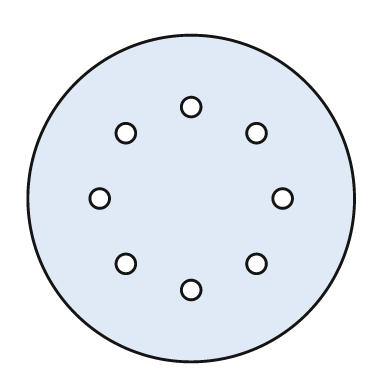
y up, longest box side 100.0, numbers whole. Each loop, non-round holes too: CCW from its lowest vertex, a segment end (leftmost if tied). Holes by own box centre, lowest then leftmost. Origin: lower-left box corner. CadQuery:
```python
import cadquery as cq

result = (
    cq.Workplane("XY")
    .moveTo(50.0, 50.0)
    .circle(50.0)
    .moveTo(50.0, 22.0)
    .circle(3.0)
    .moveTo(30.0, 30.0)
    .circle(3.0)
    .moveTo(70.0, 30.0)
    .circle(3.0)
    .moveTo(22.0, 50.0)
    .circle(3.0)
    .moveTo(78.0, 50.0)
    .circle(3.0)
    .moveTo(30.0, 70.0)
    .circle(3.0)
    .moveTo(70.0, 70.0)
    .circle(3.0)
    .moveTo(50.0, 78.0)
    .circle(3.0)
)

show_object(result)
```